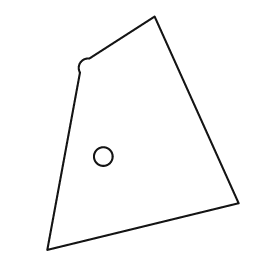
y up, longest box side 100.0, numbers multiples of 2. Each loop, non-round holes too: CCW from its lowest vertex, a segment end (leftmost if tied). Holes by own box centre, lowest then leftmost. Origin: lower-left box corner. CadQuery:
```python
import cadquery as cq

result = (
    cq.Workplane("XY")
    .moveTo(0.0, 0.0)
    .lineTo(82.0, 20.0)
    .lineTo(46.0, 100.0)
    .lineTo(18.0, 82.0)
    .threePointArc((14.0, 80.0), (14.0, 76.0))
    .close()
    .moveTo(24.0, 40.0)
    .circle(4.0)
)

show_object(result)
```